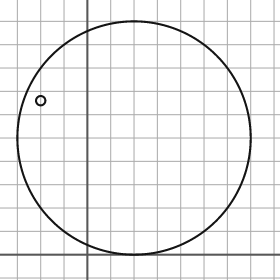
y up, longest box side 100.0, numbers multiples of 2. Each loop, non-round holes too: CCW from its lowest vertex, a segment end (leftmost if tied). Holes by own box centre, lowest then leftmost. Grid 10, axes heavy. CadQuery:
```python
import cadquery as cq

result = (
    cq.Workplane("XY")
    .moveTo(20.0, 50.0)
    .circle(50.0)
    .moveTo(-20.0, 66.0)
    .circle(2.0)
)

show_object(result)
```